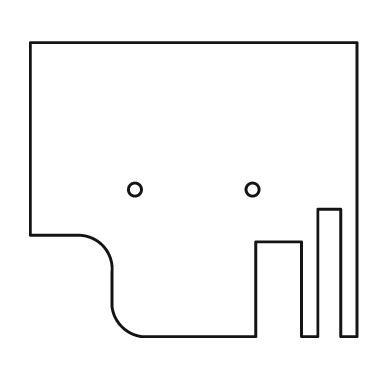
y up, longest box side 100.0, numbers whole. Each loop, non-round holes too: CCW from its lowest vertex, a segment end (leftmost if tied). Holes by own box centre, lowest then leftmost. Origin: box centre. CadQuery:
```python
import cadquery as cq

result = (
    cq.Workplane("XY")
    .moveTo(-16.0, -45.0)
    .lineTo(19.0, -45.0)
    .lineTo(19.0, -16.0)
    .lineTo(33.0, -16.0)
    .lineTo(33.0, -45.0)
    .lineTo(38.0, -45.0)
    .lineTo(38.0, -6.0)
    .lineTo(45.0, -6.0)
    .lineTo(45.0, -45.0)
    .lineTo(50.0, -45.0)
    .lineTo(50.0, 45.0)
    .lineTo(-50.0, 45.0)
    .lineTo(-50.0, -14.0)
    .lineTo(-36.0, -14.0)
    .threePointArc((-28.0, -17.0), (-25.0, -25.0))
    .lineTo(-25.0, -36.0)
    .threePointArc((-22.0, -42.0), (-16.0, -45.0))
    .close()
    .moveTo(-18.0, 0.0)
    .circle(2.0)
    .moveTo(18.0, 0.0)
    .circle(2.0)
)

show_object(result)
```